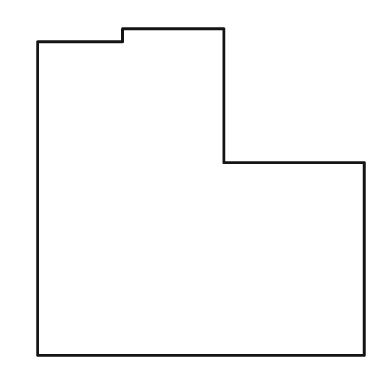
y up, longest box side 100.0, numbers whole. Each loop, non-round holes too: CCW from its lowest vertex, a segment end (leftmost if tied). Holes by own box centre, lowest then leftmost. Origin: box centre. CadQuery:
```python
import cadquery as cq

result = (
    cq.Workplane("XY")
    .moveTo(-50.0, -50.0)
    .lineTo(50.0, -50.0)
    .lineTo(50.0, 9.0)
    .lineTo(7.0, 9.0)
    .lineTo(7.0, 50.0)
    .lineTo(-24.0, 50.0)
    .lineTo(-24.0, 46.0)
    .lineTo(-50.0, 46.0)
    .close()
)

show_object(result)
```